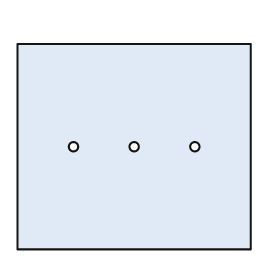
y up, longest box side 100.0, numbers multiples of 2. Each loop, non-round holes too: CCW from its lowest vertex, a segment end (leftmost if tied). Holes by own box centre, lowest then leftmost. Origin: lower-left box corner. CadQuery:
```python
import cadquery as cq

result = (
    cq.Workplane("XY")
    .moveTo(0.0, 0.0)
    .lineTo(100.0, 0.0)
    .lineTo(100.0, 88.0)
    .lineTo(0.0, 88.0)
    .close()
    .moveTo(24.0, 44.0)
    .circle(2.0)
    .moveTo(50.0, 44.0)
    .circle(2.0)
    .moveTo(76.0, 44.0)
    .circle(2.0)
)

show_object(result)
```